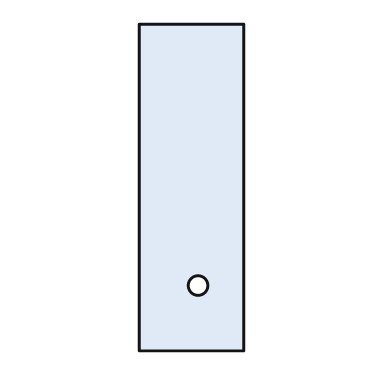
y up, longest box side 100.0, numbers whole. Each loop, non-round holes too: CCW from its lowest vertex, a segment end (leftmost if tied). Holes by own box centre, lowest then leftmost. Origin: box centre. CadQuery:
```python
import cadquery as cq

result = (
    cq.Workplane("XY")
    .moveTo(-16.0, -50.0)
    .lineTo(16.0, -50.0)
    .lineTo(16.0, 50.0)
    .lineTo(-16.0, 50.0)
    .close()
    .moveTo(2.0, -30.0)
    .circle(3.0)
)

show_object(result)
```